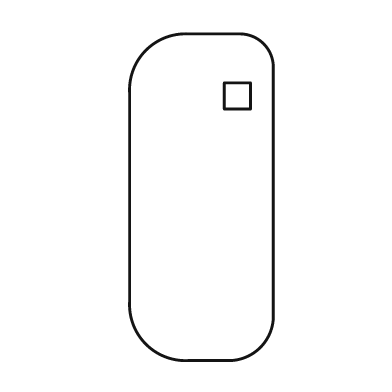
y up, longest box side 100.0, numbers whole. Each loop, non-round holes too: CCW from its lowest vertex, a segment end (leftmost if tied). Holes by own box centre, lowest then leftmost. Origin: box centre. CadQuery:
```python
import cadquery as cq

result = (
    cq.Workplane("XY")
    .moveTo(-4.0, -50.0)
    .lineTo(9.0, -50.0)
    .threePointArc((18.0, -46.0), (22.0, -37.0))
    .lineTo(22.0, 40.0)
    .threePointArc((19.0, 47.0), (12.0, 50.0))
    .lineTo(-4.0, 50.0)
    .threePointArc((-17.0, 45.0), (-22.0, 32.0))
    .lineTo(-22.0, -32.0)
    .threePointArc((-17.0, -45.0), (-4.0, -50.0))
    .close()
    .moveTo(7.0, 27.0)
    .lineTo(15.0, 27.0)
    .lineTo(15.0, 35.0)
    .lineTo(7.0, 35.0)
    .close()
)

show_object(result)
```